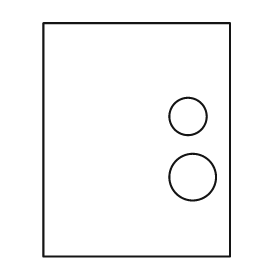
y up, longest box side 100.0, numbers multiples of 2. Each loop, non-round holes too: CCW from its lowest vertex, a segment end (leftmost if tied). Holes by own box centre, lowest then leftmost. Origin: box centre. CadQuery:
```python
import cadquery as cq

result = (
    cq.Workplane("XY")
    .moveTo(-40.0, -50.0)
    .lineTo(40.0, -50.0)
    .lineTo(40.0, 50.0)
    .lineTo(-40.0, 50.0)
    .close()
    .moveTo(24.0, -16.0)
    .circle(10.0)
    .moveTo(22.0, 10.0)
    .circle(8.0)
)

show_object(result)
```